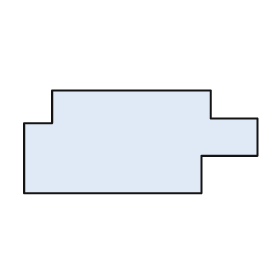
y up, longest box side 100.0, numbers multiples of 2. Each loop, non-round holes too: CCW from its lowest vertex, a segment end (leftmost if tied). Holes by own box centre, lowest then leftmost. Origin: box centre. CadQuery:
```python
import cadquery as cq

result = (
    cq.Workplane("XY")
    .moveTo(-50.0, -22.0)
    .lineTo(26.0, -22.0)
    .lineTo(26.0, -6.0)
    .lineTo(50.0, -6.0)
    .lineTo(50.0, 10.0)
    .lineTo(30.0, 10.0)
    .lineTo(30.0, 22.0)
    .lineTo(-38.0, 22.0)
    .lineTo(-38.0, 8.0)
    .lineTo(-50.0, 8.0)
    .close()
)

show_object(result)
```